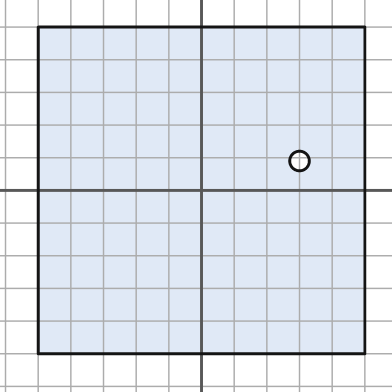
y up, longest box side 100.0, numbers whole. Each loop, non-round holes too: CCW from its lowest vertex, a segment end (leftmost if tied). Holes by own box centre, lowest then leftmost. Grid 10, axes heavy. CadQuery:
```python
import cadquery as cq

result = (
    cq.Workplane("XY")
    .moveTo(-50.0, -50.0)
    .lineTo(50.0, -50.0)
    .lineTo(50.0, 50.0)
    .lineTo(-50.0, 50.0)
    .close()
    .moveTo(30.0, 9.0)
    .circle(3.0)
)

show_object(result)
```